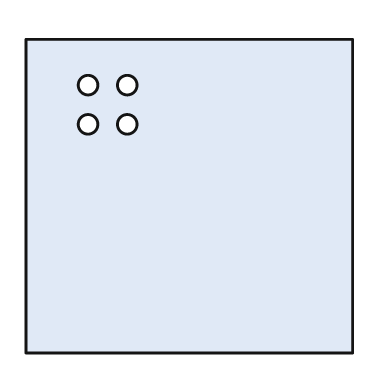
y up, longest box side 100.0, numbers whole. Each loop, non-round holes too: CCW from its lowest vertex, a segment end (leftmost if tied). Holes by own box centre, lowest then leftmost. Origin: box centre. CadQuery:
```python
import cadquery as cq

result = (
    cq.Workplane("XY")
    .moveTo(-50.0, -48.0)
    .lineTo(50.0, -48.0)
    .lineTo(50.0, 48.0)
    .lineTo(-50.0, 48.0)
    .close()
    .moveTo(-31.0, 22.0)
    .circle(3.0)
    .moveTo(-19.0, 22.0)
    .circle(3.0)
    .moveTo(-31.0, 34.0)
    .circle(3.0)
    .moveTo(-19.0, 34.0)
    .circle(3.0)
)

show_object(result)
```